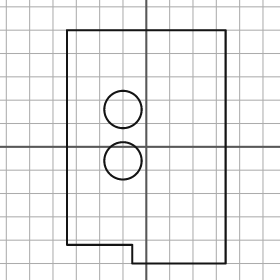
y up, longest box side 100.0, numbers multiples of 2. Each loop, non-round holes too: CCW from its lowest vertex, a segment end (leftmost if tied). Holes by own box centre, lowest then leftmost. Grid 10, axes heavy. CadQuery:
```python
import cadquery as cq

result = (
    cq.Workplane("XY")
    .moveTo(-6.0, -50.0)
    .lineTo(34.0, -50.0)
    .lineTo(34.0, 50.0)
    .lineTo(-34.0, 50.0)
    .lineTo(-34.0, -42.0)
    .lineTo(-6.0, -42.0)
    .close()
    .moveTo(-10.0, -6.0)
    .circle(8.0)
    .moveTo(-10.0, 16.0)
    .circle(8.0)
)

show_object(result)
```